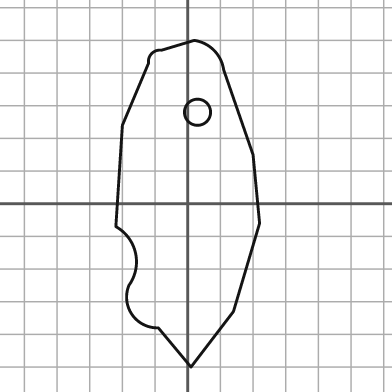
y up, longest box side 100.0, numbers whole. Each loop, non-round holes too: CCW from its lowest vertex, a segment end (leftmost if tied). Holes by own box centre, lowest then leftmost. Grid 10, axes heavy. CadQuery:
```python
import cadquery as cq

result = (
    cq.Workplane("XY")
    .moveTo(1.0, -50.0)
    .lineTo(14.0, -33.0)
    .lineTo(22.0, -6.0)
    .lineTo(20.0, 15.0)
    .lineTo(11.0, 41.0)
    .threePointArc((8.0, 47.0), (2.0, 50.0))
    .lineTo(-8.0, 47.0)
    .threePointArc((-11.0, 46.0), (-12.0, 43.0))
    .lineTo(-20.0, 24.0)
    .lineTo(-22.0, -7.0)
    .threePointArc((-16.0, -15.0), (-18.0, -25.0))
    .threePointArc((-17.0, -34.0), (-9.0, -38.0))
    .close()
    .moveTo(3.0, 28.0)
    .circle(4.0)
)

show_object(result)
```